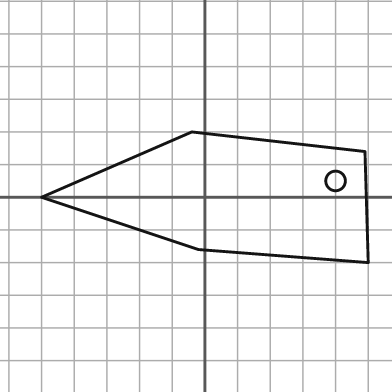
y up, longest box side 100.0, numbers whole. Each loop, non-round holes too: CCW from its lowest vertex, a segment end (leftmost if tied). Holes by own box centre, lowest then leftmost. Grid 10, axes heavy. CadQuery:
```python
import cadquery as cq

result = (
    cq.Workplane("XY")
    .moveTo(50.0, -20.0)
    .lineTo(49.0, 14.0)
    .lineTo(-4.0, 20.0)
    .lineTo(-50.0, 0.0)
    .lineTo(-2.0, -16.0)
    .close()
    .moveTo(40.0, 5.0)
    .circle(3.0)
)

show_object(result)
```